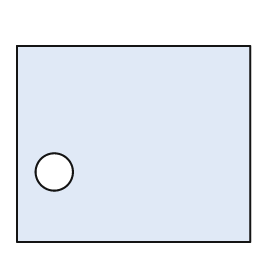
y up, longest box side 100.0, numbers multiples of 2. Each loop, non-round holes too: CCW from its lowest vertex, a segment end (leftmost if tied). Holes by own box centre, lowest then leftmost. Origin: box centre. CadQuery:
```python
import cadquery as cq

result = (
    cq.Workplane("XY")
    .moveTo(-50.0, -42.0)
    .lineTo(50.0, -42.0)
    .lineTo(50.0, 42.0)
    .lineTo(-50.0, 42.0)
    .close()
    .moveTo(-34.0, -12.0)
    .circle(8.0)
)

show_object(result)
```